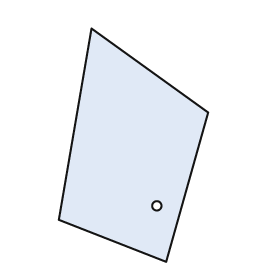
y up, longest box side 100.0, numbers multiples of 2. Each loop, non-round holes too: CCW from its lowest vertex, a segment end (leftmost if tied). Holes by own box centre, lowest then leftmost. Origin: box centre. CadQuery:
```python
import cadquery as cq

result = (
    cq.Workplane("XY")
    .moveTo(14.0, -50.0)
    .lineTo(32.0, 14.0)
    .lineTo(-18.0, 50.0)
    .lineTo(-32.0, -32.0)
    .close()
    .moveTo(10.0, -26.0)
    .circle(2.0)
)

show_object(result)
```